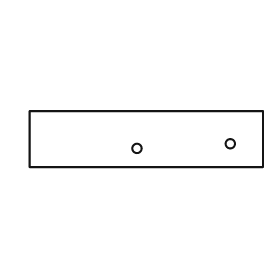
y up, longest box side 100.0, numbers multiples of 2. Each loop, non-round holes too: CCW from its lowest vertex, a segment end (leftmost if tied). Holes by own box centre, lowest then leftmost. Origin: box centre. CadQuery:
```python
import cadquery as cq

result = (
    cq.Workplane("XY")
    .moveTo(-50.0, -12.0)
    .lineTo(50.0, -12.0)
    .lineTo(50.0, 12.0)
    .lineTo(-50.0, 12.0)
    .close()
    .moveTo(-4.0, -4.0)
    .circle(2.0)
    .moveTo(36.0, -2.0)
    .circle(2.0)
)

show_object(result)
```